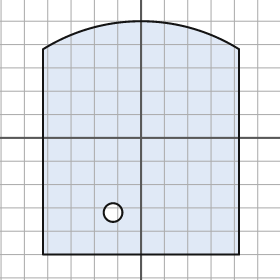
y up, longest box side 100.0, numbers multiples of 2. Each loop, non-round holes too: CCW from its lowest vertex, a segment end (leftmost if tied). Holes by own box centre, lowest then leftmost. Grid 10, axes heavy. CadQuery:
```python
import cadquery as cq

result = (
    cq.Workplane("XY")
    .moveTo(-42.0, -50.0)
    .lineTo(42.0, -50.0)
    .lineTo(42.0, 38.0)
    .threePointArc((0.0, 50.0), (-42.0, 38.0))
    .close()
    .moveTo(-12.0, -32.0)
    .circle(4.0)
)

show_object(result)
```